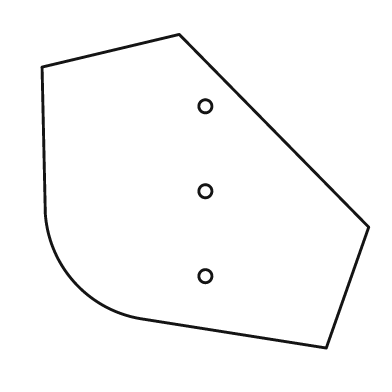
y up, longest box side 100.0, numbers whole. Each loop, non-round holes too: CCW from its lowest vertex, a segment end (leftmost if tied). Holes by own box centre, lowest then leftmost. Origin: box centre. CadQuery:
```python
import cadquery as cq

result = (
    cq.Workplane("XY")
    .moveTo(37.0, -48.0)
    .lineTo(50.0, -11.0)
    .lineTo(-8.0, 48.0)
    .lineTo(-50.0, 38.0)
    .lineTo(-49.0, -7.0)
    .threePointArc((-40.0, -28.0), (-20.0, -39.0))
    .close()
    .moveTo(0.0, -26.0)
    .circle(2.0)
    .moveTo(0.0, 0.0)
    .circle(2.0)
    .moveTo(0.0, 26.0)
    .circle(2.0)
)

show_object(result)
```